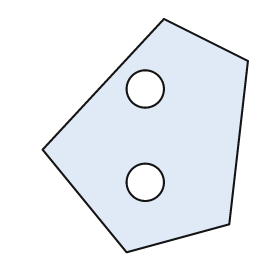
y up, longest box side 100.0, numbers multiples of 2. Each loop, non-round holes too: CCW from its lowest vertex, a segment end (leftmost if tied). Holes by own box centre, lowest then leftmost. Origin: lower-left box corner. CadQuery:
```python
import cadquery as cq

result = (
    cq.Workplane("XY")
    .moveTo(36.0, 0.0)
    .lineTo(80.0, 12.0)
    .lineTo(88.0, 82.0)
    .lineTo(52.0, 100.0)
    .lineTo(0.0, 44.0)
    .close()
    .moveTo(44.0, 30.0)
    .circle(8.0)
    .moveTo(44.0, 70.0)
    .circle(8.0)
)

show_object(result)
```